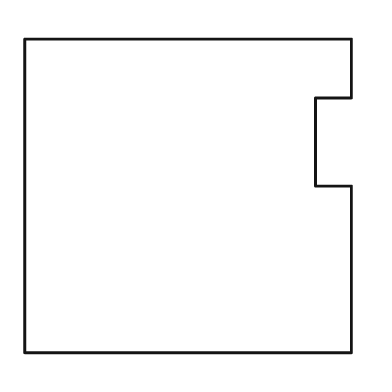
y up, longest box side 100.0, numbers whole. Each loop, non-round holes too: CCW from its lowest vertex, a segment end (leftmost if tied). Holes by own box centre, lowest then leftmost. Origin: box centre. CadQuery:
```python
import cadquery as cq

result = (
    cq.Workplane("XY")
    .moveTo(-50.0, -48.0)
    .lineTo(50.0, -48.0)
    .lineTo(50.0, 3.0)
    .lineTo(39.0, 3.0)
    .lineTo(39.0, 30.0)
    .lineTo(50.0, 30.0)
    .lineTo(50.0, 48.0)
    .lineTo(-50.0, 48.0)
    .close()
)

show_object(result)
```